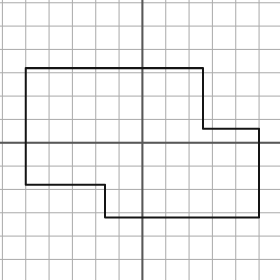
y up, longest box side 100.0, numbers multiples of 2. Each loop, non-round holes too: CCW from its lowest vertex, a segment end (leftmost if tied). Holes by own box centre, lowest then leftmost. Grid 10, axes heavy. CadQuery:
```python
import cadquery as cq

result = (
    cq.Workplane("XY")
    .moveTo(-16.0, -32.0)
    .lineTo(50.0, -32.0)
    .lineTo(50.0, 6.0)
    .lineTo(26.0, 6.0)
    .lineTo(26.0, 32.0)
    .lineTo(-50.0, 32.0)
    .lineTo(-50.0, -18.0)
    .lineTo(-16.0, -18.0)
    .close()
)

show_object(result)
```